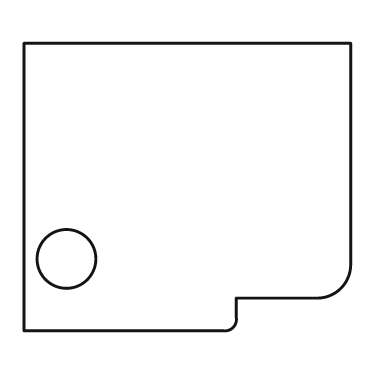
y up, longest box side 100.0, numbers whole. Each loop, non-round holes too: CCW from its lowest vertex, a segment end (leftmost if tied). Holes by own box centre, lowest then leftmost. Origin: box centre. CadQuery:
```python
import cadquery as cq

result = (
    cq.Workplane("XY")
    .moveTo(-50.0, -44.0)
    .lineTo(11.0, -44.0)
    .threePointArc((14.0, -43.0), (15.0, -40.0))
    .lineTo(15.0, -34.0)
    .lineTo(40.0, -34.0)
    .threePointArc((47.0, -31.0), (50.0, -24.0))
    .lineTo(50.0, 44.0)
    .lineTo(-50.0, 44.0)
    .close()
    .moveTo(-37.0, -22.0)
    .circle(9.0)
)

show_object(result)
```